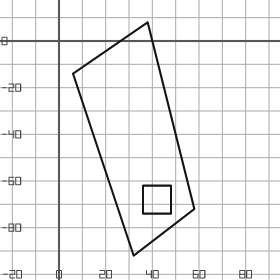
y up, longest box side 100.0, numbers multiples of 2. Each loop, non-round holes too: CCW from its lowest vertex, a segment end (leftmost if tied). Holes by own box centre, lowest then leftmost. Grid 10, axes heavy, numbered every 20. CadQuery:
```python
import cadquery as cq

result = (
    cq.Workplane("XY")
    .moveTo(32.0, -92.0)
    .lineTo(58.0, -72.0)
    .lineTo(38.0, 8.0)
    .lineTo(6.0, -14.0)
    .close()
    .moveTo(36.0, -74.0)
    .lineTo(48.0, -74.0)
    .lineTo(48.0, -62.0)
    .lineTo(36.0, -62.0)
    .close()
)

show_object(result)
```